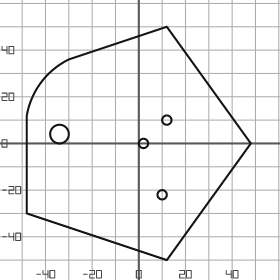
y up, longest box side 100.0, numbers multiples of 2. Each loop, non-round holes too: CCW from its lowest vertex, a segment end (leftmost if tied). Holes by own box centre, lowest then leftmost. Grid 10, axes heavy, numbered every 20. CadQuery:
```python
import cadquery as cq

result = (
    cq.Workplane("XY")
    .moveTo(12.0, -50.0)
    .lineTo(48.0, 0.0)
    .lineTo(12.0, 50.0)
    .lineTo(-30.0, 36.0)
    .threePointArc((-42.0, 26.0), (-48.0, 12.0))
    .lineTo(-48.0, -30.0)
    .close()
    .moveTo(10.0, -22.0)
    .circle(2.0)
    .moveTo(2.0, 0.0)
    .circle(2.0)
    .moveTo(-34.0, 4.0)
    .circle(4.0)
    .moveTo(12.0, 10.0)
    .circle(2.0)
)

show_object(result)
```